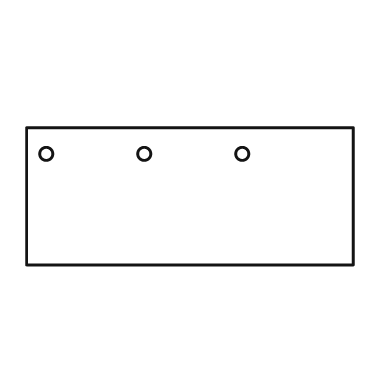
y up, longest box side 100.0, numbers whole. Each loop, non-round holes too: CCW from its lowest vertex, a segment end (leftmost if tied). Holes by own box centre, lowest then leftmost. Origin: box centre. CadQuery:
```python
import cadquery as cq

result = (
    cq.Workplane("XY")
    .moveTo(-50.0, -21.0)
    .lineTo(50.0, -21.0)
    .lineTo(50.0, 21.0)
    .lineTo(-50.0, 21.0)
    .close()
    .moveTo(-44.0, 13.0)
    .circle(2.0)
    .moveTo(-14.0, 13.0)
    .circle(2.0)
    .moveTo(16.0, 13.0)
    .circle(2.0)
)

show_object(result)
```